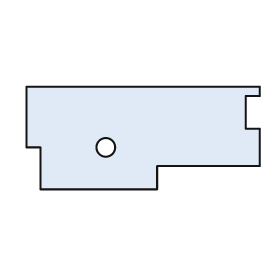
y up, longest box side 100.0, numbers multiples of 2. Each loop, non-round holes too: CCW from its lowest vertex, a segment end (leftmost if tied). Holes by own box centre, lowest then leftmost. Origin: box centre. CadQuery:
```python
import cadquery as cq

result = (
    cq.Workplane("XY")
    .moveTo(-44.0, -22.0)
    .lineTo(6.0, -22.0)
    .lineTo(6.0, -12.0)
    .lineTo(50.0, -12.0)
    .lineTo(50.0, 4.0)
    .lineTo(44.0, 4.0)
    .lineTo(44.0, 18.0)
    .lineTo(50.0, 18.0)
    .lineTo(50.0, 22.0)
    .lineTo(-50.0, 22.0)
    .lineTo(-50.0, -4.0)
    .lineTo(-44.0, -4.0)
    .close()
    .moveTo(-16.0, -4.0)
    .circle(4.0)
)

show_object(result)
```